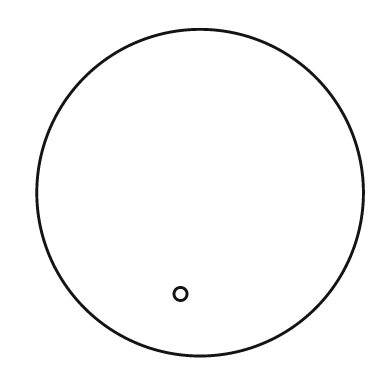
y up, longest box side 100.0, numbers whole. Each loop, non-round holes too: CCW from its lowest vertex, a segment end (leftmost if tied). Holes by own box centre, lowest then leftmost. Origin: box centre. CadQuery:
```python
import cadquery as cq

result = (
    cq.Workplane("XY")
    .moveTo(0.0, 0.0)
    .circle(50.0)
    .moveTo(-6.0, -31.0)
    .circle(2.0)
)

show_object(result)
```